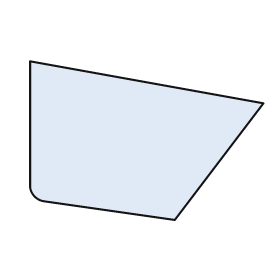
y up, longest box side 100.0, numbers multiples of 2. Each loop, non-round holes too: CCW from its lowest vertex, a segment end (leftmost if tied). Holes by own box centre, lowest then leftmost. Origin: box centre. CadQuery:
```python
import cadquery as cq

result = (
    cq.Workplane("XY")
    .moveTo(12.0, -34.0)
    .lineTo(50.0, 16.0)
    .lineTo(-50.0, 34.0)
    .lineTo(-50.0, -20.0)
    .threePointArc((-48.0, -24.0), (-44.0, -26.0))
    .close()
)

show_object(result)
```